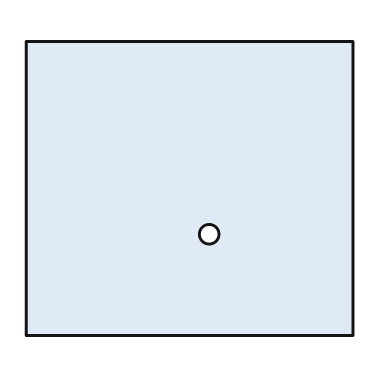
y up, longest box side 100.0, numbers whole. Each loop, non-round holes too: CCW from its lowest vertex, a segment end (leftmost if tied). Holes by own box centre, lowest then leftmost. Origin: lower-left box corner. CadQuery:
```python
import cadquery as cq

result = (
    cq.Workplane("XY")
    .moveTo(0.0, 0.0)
    .lineTo(100.0, 0.0)
    .lineTo(100.0, 90.0)
    .lineTo(0.0, 90.0)
    .close()
    .moveTo(56.0, 31.0)
    .circle(3.0)
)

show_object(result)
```